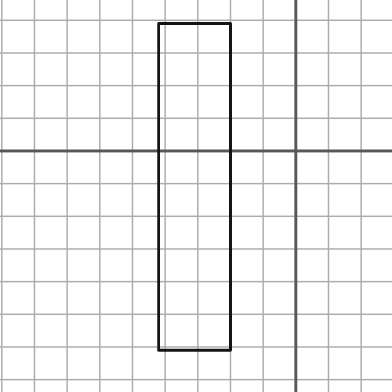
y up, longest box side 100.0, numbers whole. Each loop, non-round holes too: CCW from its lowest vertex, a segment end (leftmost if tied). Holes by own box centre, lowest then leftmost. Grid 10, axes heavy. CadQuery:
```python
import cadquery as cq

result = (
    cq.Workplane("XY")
    .moveTo(-42.0, -61.0)
    .lineTo(-20.0, -61.0)
    .lineTo(-20.0, 39.0)
    .lineTo(-42.0, 39.0)
    .close()
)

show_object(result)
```